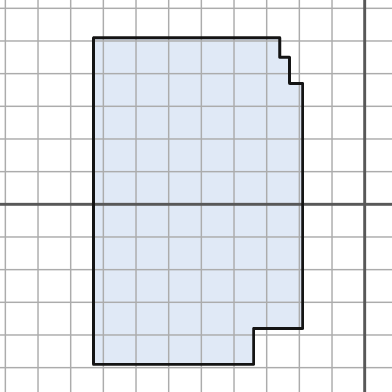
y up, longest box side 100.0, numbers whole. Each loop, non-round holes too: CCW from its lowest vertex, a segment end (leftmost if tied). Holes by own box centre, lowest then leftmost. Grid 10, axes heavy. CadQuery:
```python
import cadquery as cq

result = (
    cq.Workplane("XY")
    .moveTo(-83.0, -49.0)
    .lineTo(-34.0, -49.0)
    .lineTo(-34.0, -38.0)
    .lineTo(-19.0, -38.0)
    .lineTo(-19.0, 37.0)
    .lineTo(-23.0, 37.0)
    .lineTo(-23.0, 45.0)
    .lineTo(-26.0, 45.0)
    .lineTo(-26.0, 51.0)
    .lineTo(-83.0, 51.0)
    .close()
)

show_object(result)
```